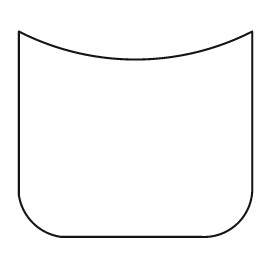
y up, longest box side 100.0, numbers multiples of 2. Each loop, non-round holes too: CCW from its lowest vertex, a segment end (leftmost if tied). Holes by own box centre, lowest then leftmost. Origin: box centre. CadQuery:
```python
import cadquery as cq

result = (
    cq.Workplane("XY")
    .moveTo(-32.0, -44.0)
    .lineTo(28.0, -44.0)
    .threePointArc((44.0, -38.0), (50.0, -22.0))
    .lineTo(50.0, 44.0)
    .threePointArc((0.0, 32.0), (-50.0, 44.0))
    .lineTo(-50.0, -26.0)
    .threePointArc((-44.0, -38.0), (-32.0, -44.0))
    .close()
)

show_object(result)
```